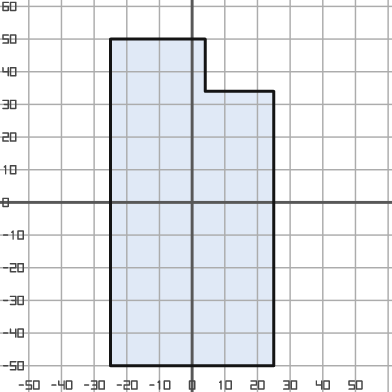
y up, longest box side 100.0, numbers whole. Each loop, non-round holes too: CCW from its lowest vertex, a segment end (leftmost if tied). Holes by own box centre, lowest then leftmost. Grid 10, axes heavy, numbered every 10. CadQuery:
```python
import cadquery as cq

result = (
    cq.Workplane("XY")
    .moveTo(-25.0, -50.0)
    .lineTo(25.0, -50.0)
    .lineTo(25.0, 34.0)
    .lineTo(4.0, 34.0)
    .lineTo(4.0, 50.0)
    .lineTo(-25.0, 50.0)
    .close()
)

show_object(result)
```